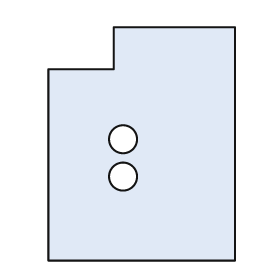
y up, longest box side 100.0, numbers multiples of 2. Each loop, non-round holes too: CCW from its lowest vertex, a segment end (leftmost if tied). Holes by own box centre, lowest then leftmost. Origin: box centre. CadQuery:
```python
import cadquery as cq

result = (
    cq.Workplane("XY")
    .moveTo(-40.0, -50.0)
    .lineTo(40.0, -50.0)
    .lineTo(40.0, 50.0)
    .lineTo(-12.0, 50.0)
    .lineTo(-12.0, 32.0)
    .lineTo(-40.0, 32.0)
    .close()
    .moveTo(-8.0, -14.0)
    .circle(6.0)
    .moveTo(-8.0, 2.0)
    .circle(6.0)
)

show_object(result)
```